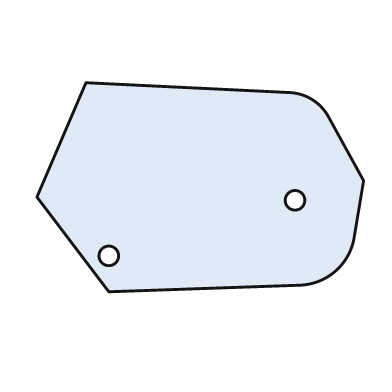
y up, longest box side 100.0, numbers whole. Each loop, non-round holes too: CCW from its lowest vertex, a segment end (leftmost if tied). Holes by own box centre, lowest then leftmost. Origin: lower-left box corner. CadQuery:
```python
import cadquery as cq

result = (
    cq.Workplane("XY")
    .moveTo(22.0, 0.0)
    .lineTo(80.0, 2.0)
    .threePointArc((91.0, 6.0), (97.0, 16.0))
    .lineTo(100.0, 34.0)
    .lineTo(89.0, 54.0)
    .threePointArc((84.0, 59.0), (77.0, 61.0))
    .lineTo(15.0, 64.0)
    .lineTo(0.0, 29.0)
    .close()
    .moveTo(22.0, 11.0)
    .circle(3.0)
    .moveTo(79.0, 28.0)
    .circle(3.0)
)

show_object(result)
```